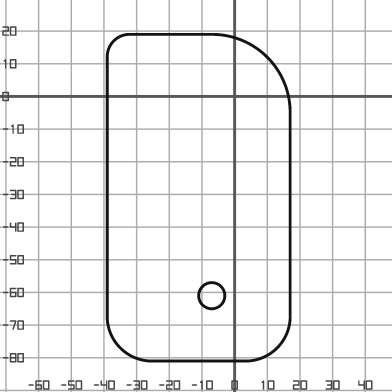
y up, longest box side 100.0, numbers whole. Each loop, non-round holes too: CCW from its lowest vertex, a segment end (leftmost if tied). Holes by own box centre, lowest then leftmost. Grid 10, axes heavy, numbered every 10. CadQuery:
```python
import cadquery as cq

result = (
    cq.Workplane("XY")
    .moveTo(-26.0, -81.0)
    .lineTo(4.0, -81.0)
    .threePointArc((13.0, -77.0), (17.0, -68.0))
    .lineTo(17.0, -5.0)
    .threePointArc((10.0, 12.0), (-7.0, 19.0))
    .lineTo(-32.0, 19.0)
    .threePointArc((-37.0, 17.0), (-39.0, 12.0))
    .lineTo(-39.0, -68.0)
    .threePointArc((-35.0, -77.0), (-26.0, -81.0))
    .close()
    .moveTo(-7.0, -61.0)
    .circle(4.0)
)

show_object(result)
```